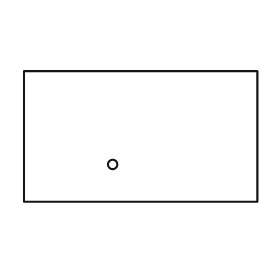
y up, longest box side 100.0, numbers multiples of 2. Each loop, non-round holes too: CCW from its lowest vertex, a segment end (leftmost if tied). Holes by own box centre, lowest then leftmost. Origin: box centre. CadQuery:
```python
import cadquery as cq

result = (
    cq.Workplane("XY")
    .moveTo(-50.0, -28.0)
    .lineTo(50.0, -28.0)
    .lineTo(50.0, 28.0)
    .lineTo(-50.0, 28.0)
    .close()
    .moveTo(-12.0, -12.0)
    .circle(2.0)
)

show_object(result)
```